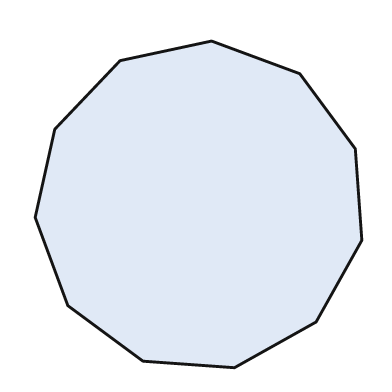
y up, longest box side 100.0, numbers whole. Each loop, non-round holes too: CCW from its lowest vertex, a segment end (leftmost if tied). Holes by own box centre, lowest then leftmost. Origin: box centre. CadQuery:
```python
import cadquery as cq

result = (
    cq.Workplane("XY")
    .moveTo(11.0, -50.0)
    .lineTo(36.0, -36.0)
    .lineTo(50.0, -11.0)
    .lineTo(48.0, 17.0)
    .lineTo(31.0, 40.0)
    .lineTo(4.0, 50.0)
    .lineTo(-24.0, 44.0)
    .lineTo(-44.0, 23.0)
    .lineTo(-50.0, -4.0)
    .lineTo(-40.0, -31.0)
    .lineTo(-17.0, -48.0)
    .close()
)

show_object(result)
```